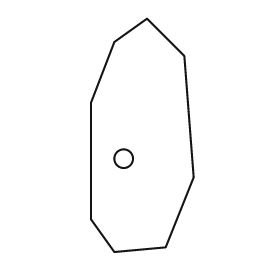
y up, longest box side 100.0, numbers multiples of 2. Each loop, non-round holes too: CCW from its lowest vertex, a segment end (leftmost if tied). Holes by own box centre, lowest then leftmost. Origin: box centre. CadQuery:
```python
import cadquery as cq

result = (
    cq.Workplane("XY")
    .moveTo(-12.0, -50.0)
    .lineTo(10.0, -48.0)
    .lineTo(22.0, -18.0)
    .lineTo(18.0, 34.0)
    .lineTo(2.0, 50.0)
    .lineTo(-12.0, 40.0)
    .lineTo(-22.0, 14.0)
    .lineTo(-22.0, -36.0)
    .close()
    .moveTo(-8.0, -10.0)
    .circle(4.0)
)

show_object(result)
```